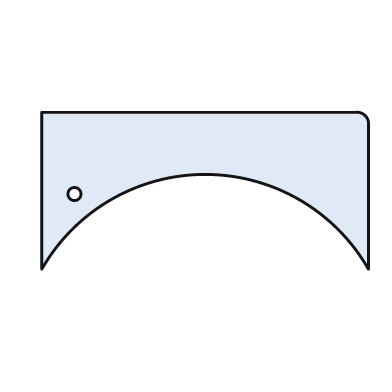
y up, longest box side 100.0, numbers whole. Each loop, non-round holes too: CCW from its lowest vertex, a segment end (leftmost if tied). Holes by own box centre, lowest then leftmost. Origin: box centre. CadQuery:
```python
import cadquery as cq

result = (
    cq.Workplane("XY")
    .moveTo(-50.0, -24.0)
    .threePointArc((0.0, 5.0), (50.0, -24.0))
    .lineTo(50.0, 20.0)
    .threePointArc((49.0, 23.0), (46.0, 24.0))
    .lineTo(-50.0, 24.0)
    .close()
    .moveTo(-40.0, -1.0)
    .circle(2.0)
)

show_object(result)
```